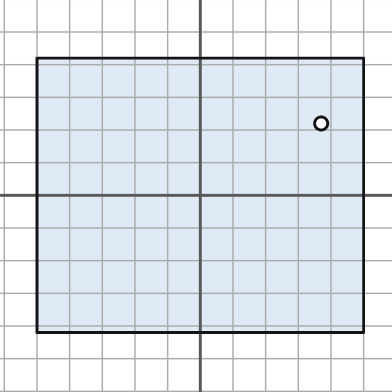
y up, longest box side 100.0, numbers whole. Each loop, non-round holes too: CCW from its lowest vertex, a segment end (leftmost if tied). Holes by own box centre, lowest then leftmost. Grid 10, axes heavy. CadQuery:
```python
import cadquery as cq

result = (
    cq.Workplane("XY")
    .moveTo(-50.0, -42.0)
    .lineTo(50.0, -42.0)
    .lineTo(50.0, 42.0)
    .lineTo(-50.0, 42.0)
    .close()
    .moveTo(37.0, 22.0)
    .circle(2.0)
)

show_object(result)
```